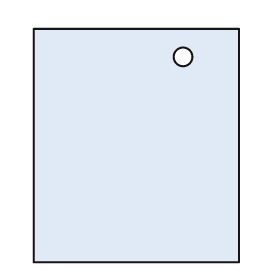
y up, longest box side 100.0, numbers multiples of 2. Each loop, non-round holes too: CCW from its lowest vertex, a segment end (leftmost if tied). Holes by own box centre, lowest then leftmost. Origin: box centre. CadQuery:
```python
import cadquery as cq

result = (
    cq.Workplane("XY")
    .moveTo(-44.0, -50.0)
    .lineTo(44.0, -50.0)
    .lineTo(44.0, 50.0)
    .lineTo(-44.0, 50.0)
    .close()
    .moveTo(20.0, 38.0)
    .circle(4.0)
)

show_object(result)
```